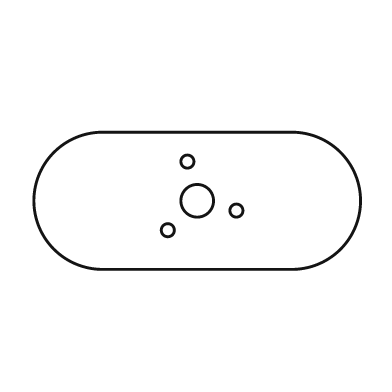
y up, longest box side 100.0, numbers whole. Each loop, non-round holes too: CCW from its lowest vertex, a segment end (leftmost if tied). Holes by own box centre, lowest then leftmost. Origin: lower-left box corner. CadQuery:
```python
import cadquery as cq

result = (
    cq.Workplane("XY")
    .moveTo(21.0, 0.0)
    .lineTo(79.0, 0.0)
    .threePointArc((100.0, 21.0), (79.0, 42.0))
    .lineTo(21.0, 42.0)
    .threePointArc((0.0, 21.0), (21.0, 0.0))
    .close()
    .moveTo(41.0, 12.0)
    .circle(2.0)
    .moveTo(62.0, 18.0)
    .circle(2.0)
    .moveTo(50.0, 21.0)
    .circle(5.0)
    .moveTo(47.0, 33.0)
    .circle(2.0)
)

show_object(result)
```